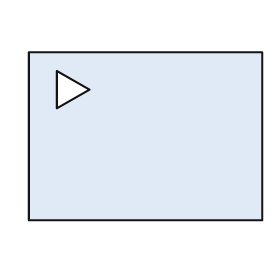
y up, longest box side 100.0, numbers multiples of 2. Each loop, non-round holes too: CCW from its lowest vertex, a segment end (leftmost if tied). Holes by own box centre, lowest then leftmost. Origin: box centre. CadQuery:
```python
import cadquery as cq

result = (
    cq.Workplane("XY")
    .moveTo(-50.0, -36.0)
    .lineTo(50.0, -36.0)
    .lineTo(50.0, 36.0)
    .lineTo(-50.0, 36.0)
    .close()
    .moveTo(-38.0, 12.0)
    .lineTo(-24.0, 20.0)
    .lineTo(-38.0, 28.0)
    .close()
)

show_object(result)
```